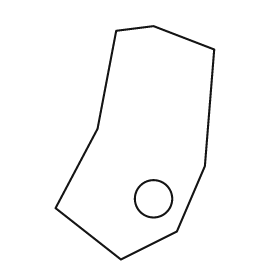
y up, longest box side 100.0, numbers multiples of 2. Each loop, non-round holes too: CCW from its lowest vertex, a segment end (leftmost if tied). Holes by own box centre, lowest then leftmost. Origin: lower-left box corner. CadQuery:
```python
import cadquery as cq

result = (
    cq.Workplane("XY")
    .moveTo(28.0, 0.0)
    .lineTo(52.0, 12.0)
    .lineTo(64.0, 40.0)
    .lineTo(68.0, 90.0)
    .lineTo(42.0, 100.0)
    .lineTo(26.0, 98.0)
    .lineTo(18.0, 56.0)
    .lineTo(0.0, 22.0)
    .close()
    .moveTo(42.0, 26.0)
    .circle(8.0)
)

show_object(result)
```